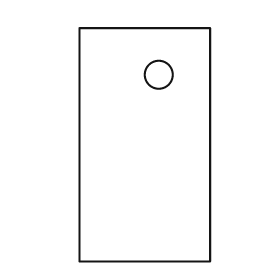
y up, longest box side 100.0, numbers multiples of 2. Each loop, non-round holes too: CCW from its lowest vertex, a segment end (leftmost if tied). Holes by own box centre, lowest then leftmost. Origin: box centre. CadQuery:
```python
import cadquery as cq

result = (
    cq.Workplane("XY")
    .moveTo(-28.0, -50.0)
    .lineTo(28.0, -50.0)
    .lineTo(28.0, 50.0)
    .lineTo(-28.0, 50.0)
    .close()
    .moveTo(6.0, 30.0)
    .circle(6.0)
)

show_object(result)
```